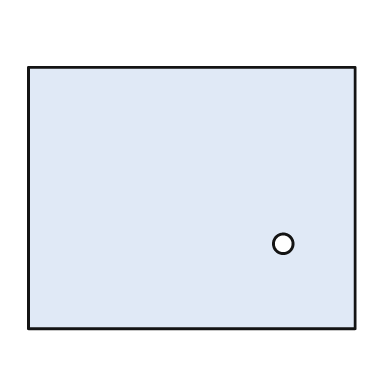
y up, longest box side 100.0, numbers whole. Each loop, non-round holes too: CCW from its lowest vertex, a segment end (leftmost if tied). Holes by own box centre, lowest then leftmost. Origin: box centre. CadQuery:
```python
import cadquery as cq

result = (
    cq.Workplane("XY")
    .moveTo(-50.0, -40.0)
    .lineTo(50.0, -40.0)
    .lineTo(50.0, 40.0)
    .lineTo(-50.0, 40.0)
    .close()
    .moveTo(28.0, -14.0)
    .circle(3.0)
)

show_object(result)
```